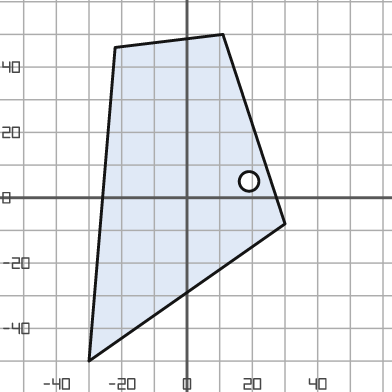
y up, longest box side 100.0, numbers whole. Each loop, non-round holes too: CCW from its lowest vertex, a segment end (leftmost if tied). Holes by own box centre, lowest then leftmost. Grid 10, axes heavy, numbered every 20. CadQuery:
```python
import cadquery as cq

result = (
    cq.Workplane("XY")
    .moveTo(-30.0, -50.0)
    .lineTo(30.0, -8.0)
    .lineTo(11.0, 50.0)
    .lineTo(-22.0, 46.0)
    .close()
    .moveTo(19.0, 5.0)
    .circle(3.0)
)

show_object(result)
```